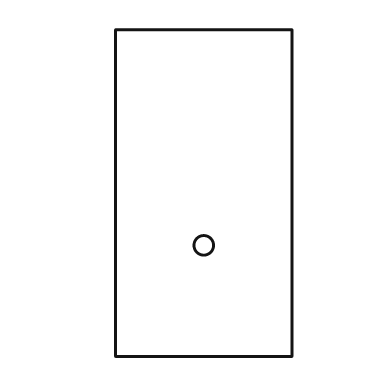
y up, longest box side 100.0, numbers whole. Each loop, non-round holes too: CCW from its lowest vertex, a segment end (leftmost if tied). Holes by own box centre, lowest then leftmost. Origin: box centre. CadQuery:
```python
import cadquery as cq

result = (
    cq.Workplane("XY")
    .moveTo(-27.0, -50.0)
    .lineTo(27.0, -50.0)
    .lineTo(27.0, 50.0)
    .lineTo(-27.0, 50.0)
    .close()
    .moveTo(0.0, -16.0)
    .circle(3.0)
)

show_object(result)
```